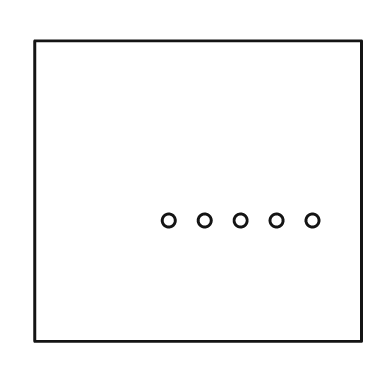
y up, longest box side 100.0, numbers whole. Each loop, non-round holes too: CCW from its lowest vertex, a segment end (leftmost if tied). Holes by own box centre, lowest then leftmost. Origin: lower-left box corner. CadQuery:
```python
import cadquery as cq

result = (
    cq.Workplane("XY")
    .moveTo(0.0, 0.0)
    .lineTo(100.0, 0.0)
    .lineTo(100.0, 92.0)
    .lineTo(0.0, 92.0)
    .close()
    .moveTo(41.0, 37.0)
    .circle(2.0)
    .moveTo(52.0, 37.0)
    .circle(2.0)
    .moveTo(63.0, 37.0)
    .circle(2.0)
    .moveTo(74.0, 37.0)
    .circle(2.0)
    .moveTo(85.0, 37.0)
    .circle(2.0)
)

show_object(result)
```